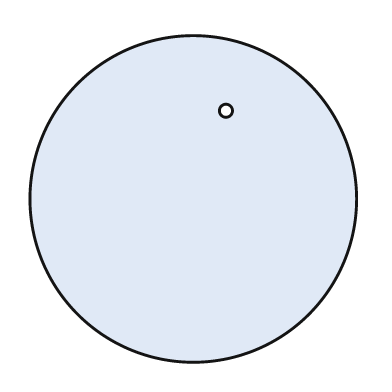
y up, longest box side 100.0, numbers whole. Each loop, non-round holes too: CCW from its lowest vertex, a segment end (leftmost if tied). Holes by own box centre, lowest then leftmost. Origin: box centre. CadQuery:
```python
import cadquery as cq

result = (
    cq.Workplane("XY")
    .moveTo(0.0, 0.0)
    .circle(50.0)
    .moveTo(10.0, 27.0)
    .circle(2.0)
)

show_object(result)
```